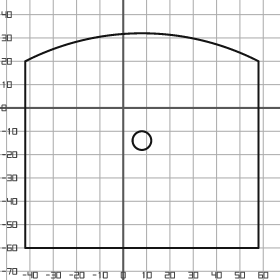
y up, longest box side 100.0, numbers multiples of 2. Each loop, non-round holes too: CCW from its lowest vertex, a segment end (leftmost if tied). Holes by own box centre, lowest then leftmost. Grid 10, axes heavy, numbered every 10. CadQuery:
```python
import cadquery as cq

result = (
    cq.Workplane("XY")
    .moveTo(-42.0, -60.0)
    .lineTo(58.0, -60.0)
    .lineTo(58.0, 20.0)
    .threePointArc((8.0, 32.0), (-42.0, 20.0))
    .close()
    .moveTo(8.0, -14.0)
    .circle(4.0)
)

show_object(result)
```